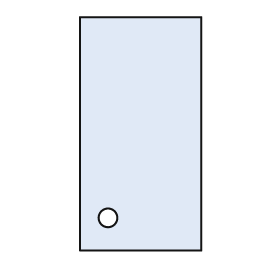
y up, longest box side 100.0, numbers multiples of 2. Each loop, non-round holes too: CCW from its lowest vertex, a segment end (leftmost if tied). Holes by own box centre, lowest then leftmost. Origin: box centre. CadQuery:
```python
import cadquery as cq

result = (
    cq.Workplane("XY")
    .moveTo(-26.0, -50.0)
    .lineTo(26.0, -50.0)
    .lineTo(26.0, 50.0)
    .lineTo(-26.0, 50.0)
    .close()
    .moveTo(-14.0, -36.0)
    .circle(4.0)
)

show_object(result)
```